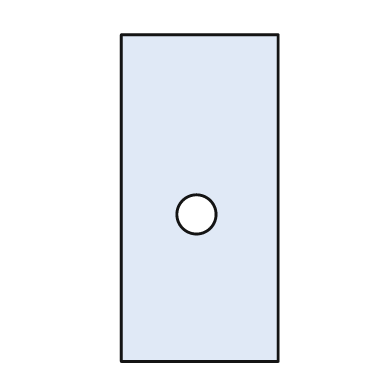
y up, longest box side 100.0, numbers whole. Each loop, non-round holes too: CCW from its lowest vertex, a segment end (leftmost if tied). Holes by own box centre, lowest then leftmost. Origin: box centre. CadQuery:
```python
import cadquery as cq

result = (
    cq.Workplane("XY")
    .moveTo(-24.0, -50.0)
    .lineTo(24.0, -50.0)
    .lineTo(24.0, 50.0)
    .lineTo(-24.0, 50.0)
    .close()
    .moveTo(-1.0, -5.0)
    .circle(6.0)
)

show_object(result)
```